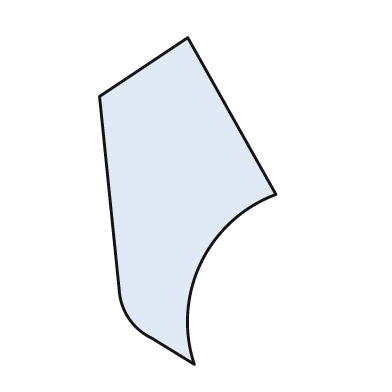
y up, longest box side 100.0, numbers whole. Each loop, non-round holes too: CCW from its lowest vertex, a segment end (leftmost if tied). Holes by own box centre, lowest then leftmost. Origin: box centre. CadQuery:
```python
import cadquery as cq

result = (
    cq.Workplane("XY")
    .moveTo(2.0, -50.0)
    .threePointArc((4.0, -19.0), (27.0, 2.0))
    .lineTo(0.0, 50.0)
    .lineTo(-27.0, 32.0)
    .lineTo(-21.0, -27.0)
    .threePointArc((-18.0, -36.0), (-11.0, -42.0))
    .close()
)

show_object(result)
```